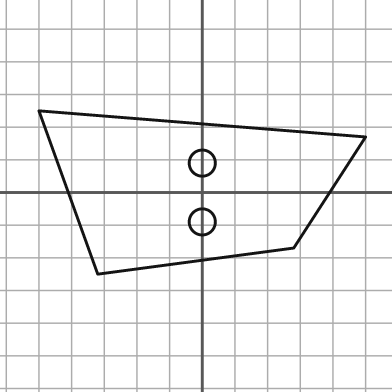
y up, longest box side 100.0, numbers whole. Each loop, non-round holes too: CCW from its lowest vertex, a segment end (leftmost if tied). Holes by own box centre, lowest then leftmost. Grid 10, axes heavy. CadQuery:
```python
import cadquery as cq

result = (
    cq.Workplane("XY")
    .moveTo(-32.0, -25.0)
    .lineTo(28.0, -17.0)
    .lineTo(50.0, 17.0)
    .lineTo(-50.0, 25.0)
    .close()
    .moveTo(0.0, -9.0)
    .circle(4.0)
    .moveTo(0.0, 9.0)
    .circle(4.0)
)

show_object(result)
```